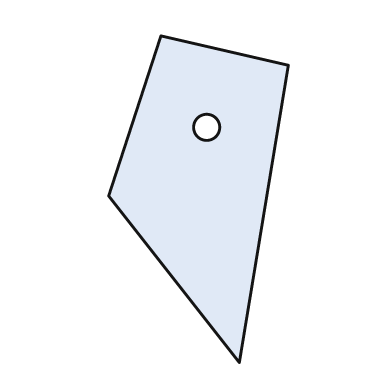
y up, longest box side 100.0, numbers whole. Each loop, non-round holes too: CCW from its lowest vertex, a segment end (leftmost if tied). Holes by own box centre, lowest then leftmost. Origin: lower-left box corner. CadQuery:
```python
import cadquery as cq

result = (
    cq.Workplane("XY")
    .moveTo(40.0, 0.0)
    .lineTo(55.0, 91.0)
    .lineTo(16.0, 100.0)
    .lineTo(0.0, 51.0)
    .close()
    .moveTo(30.0, 72.0)
    .circle(4.0)
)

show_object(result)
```